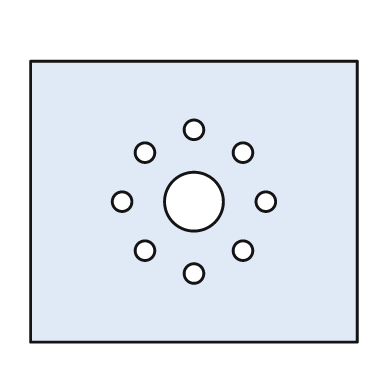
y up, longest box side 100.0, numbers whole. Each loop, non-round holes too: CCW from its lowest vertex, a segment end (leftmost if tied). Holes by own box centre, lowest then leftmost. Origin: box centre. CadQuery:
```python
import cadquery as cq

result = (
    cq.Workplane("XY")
    .moveTo(-50.0, -43.0)
    .lineTo(50.0, -43.0)
    .lineTo(50.0, 43.0)
    .lineTo(-50.0, 43.0)
    .close()
    .moveTo(0.0, -22.0)
    .circle(3.0)
    .moveTo(-15.0, -15.0)
    .circle(3.0)
    .moveTo(15.0, -15.0)
    .circle(3.0)
    .moveTo(-22.0, 0.0)
    .circle(3.0)
    .moveTo(0.0, 0.0)
    .circle(9.0)
    .moveTo(22.0, 0.0)
    .circle(3.0)
    .moveTo(-15.0, 15.0)
    .circle(3.0)
    .moveTo(15.0, 15.0)
    .circle(3.0)
    .moveTo(0.0, 22.0)
    .circle(3.0)
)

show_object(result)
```